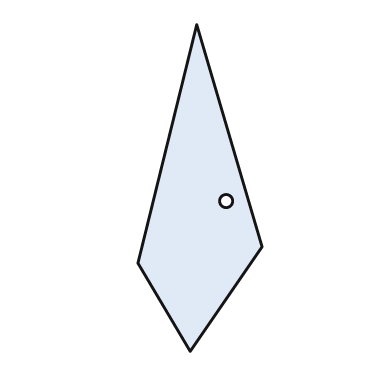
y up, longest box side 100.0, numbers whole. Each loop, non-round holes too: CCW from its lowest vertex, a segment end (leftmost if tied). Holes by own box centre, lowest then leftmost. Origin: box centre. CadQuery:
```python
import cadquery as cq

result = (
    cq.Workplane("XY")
    .moveTo(-3.0, -50.0)
    .lineTo(19.0, -18.0)
    .lineTo(-1.0, 50.0)
    .lineTo(-19.0, -23.0)
    .close()
    .moveTo(8.0, -4.0)
    .circle(2.0)
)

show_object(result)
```